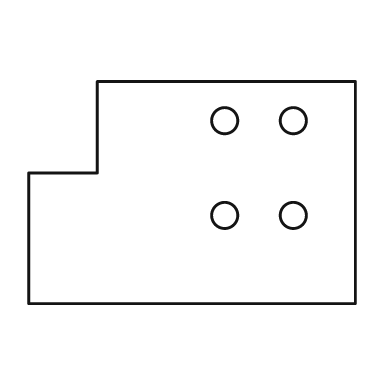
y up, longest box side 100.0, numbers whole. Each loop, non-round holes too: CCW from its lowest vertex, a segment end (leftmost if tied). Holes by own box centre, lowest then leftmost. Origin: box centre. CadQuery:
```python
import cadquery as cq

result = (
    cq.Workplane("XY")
    .moveTo(-50.0, -34.0)
    .lineTo(50.0, -34.0)
    .lineTo(50.0, 34.0)
    .lineTo(-29.0, 34.0)
    .lineTo(-29.0, 6.0)
    .lineTo(-50.0, 6.0)
    .close()
    .moveTo(10.0, -7.0)
    .circle(4.0)
    .moveTo(31.0, -7.0)
    .circle(4.0)
    .moveTo(10.0, 22.0)
    .circle(4.0)
    .moveTo(31.0, 22.0)
    .circle(4.0)
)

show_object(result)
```